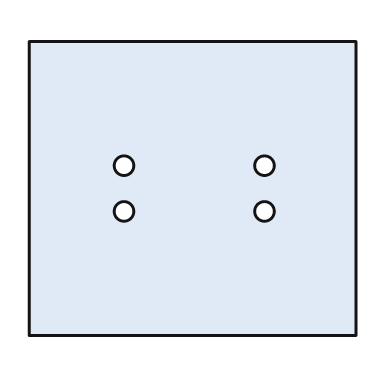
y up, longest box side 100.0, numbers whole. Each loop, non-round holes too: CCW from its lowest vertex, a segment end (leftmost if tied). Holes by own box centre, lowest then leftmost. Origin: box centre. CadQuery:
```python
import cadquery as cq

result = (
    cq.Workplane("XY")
    .moveTo(-50.0, -45.0)
    .lineTo(50.0, -45.0)
    .lineTo(50.0, 45.0)
    .lineTo(-50.0, 45.0)
    .close()
    .moveTo(-21.0, -7.0)
    .circle(3.0)
    .moveTo(22.0, -7.0)
    .circle(3.0)
    .moveTo(-21.0, 7.0)
    .circle(3.0)
    .moveTo(22.0, 7.0)
    .circle(3.0)
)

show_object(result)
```